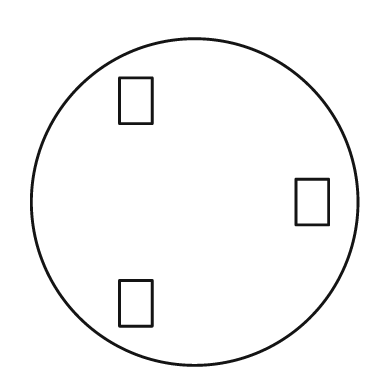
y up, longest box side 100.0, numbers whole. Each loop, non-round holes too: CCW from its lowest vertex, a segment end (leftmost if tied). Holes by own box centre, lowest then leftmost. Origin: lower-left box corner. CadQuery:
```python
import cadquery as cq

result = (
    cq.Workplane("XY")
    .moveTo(50.0, 50.0)
    .circle(50.0)
    .moveTo(27.0, 12.0)
    .lineTo(37.0, 12.0)
    .lineTo(37.0, 26.0)
    .lineTo(27.0, 26.0)
    .close()
    .moveTo(81.0, 43.0)
    .lineTo(91.0, 43.0)
    .lineTo(91.0, 57.0)
    .lineTo(81.0, 57.0)
    .close()
    .moveTo(27.0, 74.0)
    .lineTo(37.0, 74.0)
    .lineTo(37.0, 88.0)
    .lineTo(27.0, 88.0)
    .close()
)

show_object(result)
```